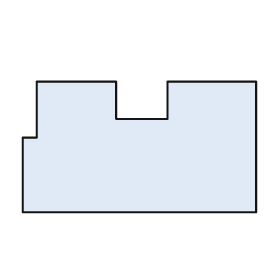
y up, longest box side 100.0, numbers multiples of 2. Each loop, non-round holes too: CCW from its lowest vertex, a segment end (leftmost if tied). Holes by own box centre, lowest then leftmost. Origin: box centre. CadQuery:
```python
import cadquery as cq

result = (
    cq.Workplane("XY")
    .moveTo(-50.0, -28.0)
    .lineTo(50.0, -28.0)
    .lineTo(50.0, 28.0)
    .lineTo(12.0, 28.0)
    .lineTo(12.0, 12.0)
    .lineTo(-10.0, 12.0)
    .lineTo(-10.0, 28.0)
    .lineTo(-44.0, 28.0)
    .lineTo(-44.0, 4.0)
    .lineTo(-50.0, 4.0)
    .close()
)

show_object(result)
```